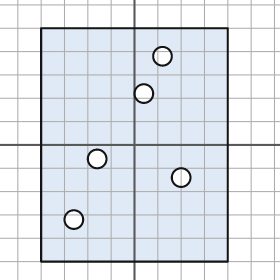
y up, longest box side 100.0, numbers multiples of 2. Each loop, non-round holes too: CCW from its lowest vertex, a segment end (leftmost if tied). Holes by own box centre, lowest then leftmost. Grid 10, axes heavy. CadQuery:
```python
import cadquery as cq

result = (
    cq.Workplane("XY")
    .moveTo(-40.0, -50.0)
    .lineTo(40.0, -50.0)
    .lineTo(40.0, 50.0)
    .lineTo(-40.0, 50.0)
    .close()
    .moveTo(-26.0, -32.0)
    .circle(4.0)
    .moveTo(20.0, -14.0)
    .circle(4.0)
    .moveTo(-16.0, -6.0)
    .circle(4.0)
    .moveTo(4.0, 22.0)
    .circle(4.0)
    .moveTo(12.0, 38.0)
    .circle(4.0)
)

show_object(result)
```